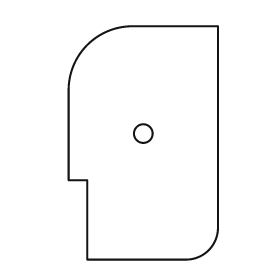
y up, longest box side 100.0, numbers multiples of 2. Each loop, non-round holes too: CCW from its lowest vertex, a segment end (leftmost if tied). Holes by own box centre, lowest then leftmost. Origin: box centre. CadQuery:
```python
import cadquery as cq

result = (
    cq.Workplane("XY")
    .moveTo(-24.0, -50.0)
    .lineTo(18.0, -50.0)
    .threePointArc((28.0, -46.0), (32.0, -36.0))
    .lineTo(32.0, 50.0)
    .lineTo(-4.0, 50.0)
    .threePointArc((-24.0, 42.0), (-32.0, 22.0))
    .lineTo(-32.0, -16.0)
    .lineTo(-24.0, -16.0)
    .close()
    .moveTo(0.0, 4.0)
    .circle(4.0)
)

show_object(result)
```